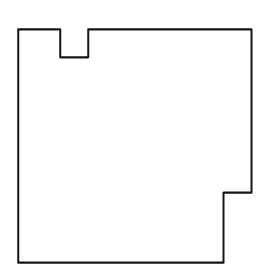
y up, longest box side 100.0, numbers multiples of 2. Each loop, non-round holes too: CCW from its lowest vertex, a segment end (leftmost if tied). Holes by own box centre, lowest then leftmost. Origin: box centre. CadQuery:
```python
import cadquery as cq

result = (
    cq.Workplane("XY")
    .moveTo(-50.0, -50.0)
    .lineTo(38.0, -50.0)
    .lineTo(38.0, -20.0)
    .lineTo(50.0, -20.0)
    .lineTo(50.0, 50.0)
    .lineTo(-20.0, 50.0)
    .lineTo(-20.0, 38.0)
    .lineTo(-32.0, 38.0)
    .lineTo(-32.0, 50.0)
    .lineTo(-50.0, 50.0)
    .close()
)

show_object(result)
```